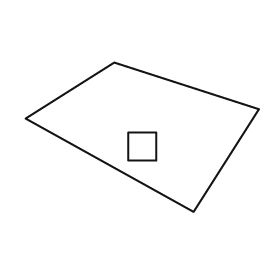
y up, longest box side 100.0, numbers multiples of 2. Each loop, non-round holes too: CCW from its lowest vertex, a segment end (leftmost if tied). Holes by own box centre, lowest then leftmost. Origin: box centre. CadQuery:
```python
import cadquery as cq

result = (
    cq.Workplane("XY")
    .moveTo(22.0, -32.0)
    .lineTo(50.0, 12.0)
    .lineTo(-12.0, 32.0)
    .lineTo(-50.0, 8.0)
    .close()
    .moveTo(-6.0, -10.0)
    .lineTo(6.0, -10.0)
    .lineTo(6.0, 2.0)
    .lineTo(-6.0, 2.0)
    .close()
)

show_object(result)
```